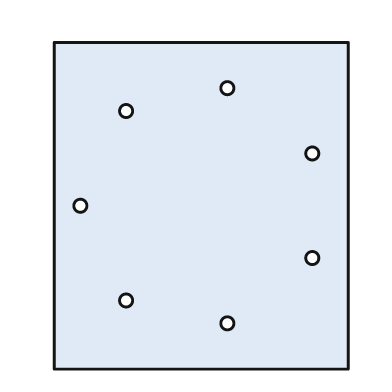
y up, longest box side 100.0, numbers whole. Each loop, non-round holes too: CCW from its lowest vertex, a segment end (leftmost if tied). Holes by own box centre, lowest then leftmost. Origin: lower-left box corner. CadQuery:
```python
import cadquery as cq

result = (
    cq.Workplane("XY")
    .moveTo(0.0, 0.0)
    .lineTo(90.0, 0.0)
    .lineTo(90.0, 100.0)
    .lineTo(0.0, 100.0)
    .close()
    .moveTo(53.0, 14.0)
    .circle(2.0)
    .moveTo(22.0, 21.0)
    .circle(2.0)
    .moveTo(79.0, 34.0)
    .circle(2.0)
    .moveTo(8.0, 50.0)
    .circle(2.0)
    .moveTo(79.0, 66.0)
    .circle(2.0)
    .moveTo(22.0, 79.0)
    .circle(2.0)
    .moveTo(53.0, 86.0)
    .circle(2.0)
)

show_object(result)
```